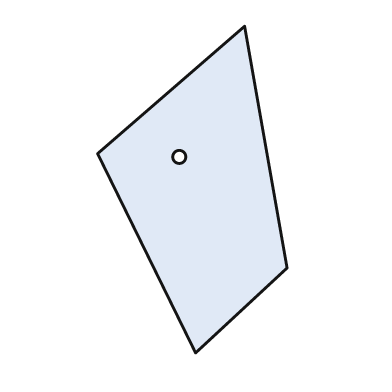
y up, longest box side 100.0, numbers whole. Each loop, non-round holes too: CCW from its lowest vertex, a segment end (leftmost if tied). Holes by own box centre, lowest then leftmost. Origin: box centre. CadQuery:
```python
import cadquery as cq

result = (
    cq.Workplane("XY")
    .moveTo(1.0, -50.0)
    .lineTo(29.0, -24.0)
    .lineTo(16.0, 50.0)
    .lineTo(-29.0, 11.0)
    .close()
    .moveTo(-4.0, 10.0)
    .circle(2.0)
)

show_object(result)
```